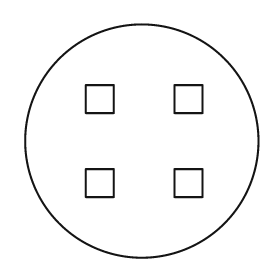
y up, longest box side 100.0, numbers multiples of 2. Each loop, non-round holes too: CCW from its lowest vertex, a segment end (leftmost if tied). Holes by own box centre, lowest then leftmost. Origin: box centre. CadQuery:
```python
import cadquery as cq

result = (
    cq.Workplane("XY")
    .moveTo(0.0, 0.0)
    .circle(50.0)
    .moveTo(-24.0, -24.0)
    .lineTo(-12.0, -24.0)
    .lineTo(-12.0, -12.0)
    .lineTo(-24.0, -12.0)
    .close()
    .moveTo(14.0, -24.0)
    .lineTo(26.0, -24.0)
    .lineTo(26.0, -12.0)
    .lineTo(14.0, -12.0)
    .close()
    .moveTo(-24.0, 12.0)
    .lineTo(-12.0, 12.0)
    .lineTo(-12.0, 24.0)
    .lineTo(-24.0, 24.0)
    .close()
    .moveTo(14.0, 12.0)
    .lineTo(26.0, 12.0)
    .lineTo(26.0, 24.0)
    .lineTo(14.0, 24.0)
    .close()
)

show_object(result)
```